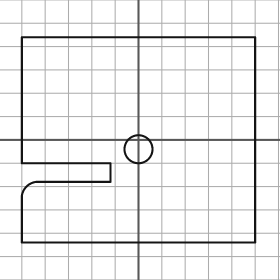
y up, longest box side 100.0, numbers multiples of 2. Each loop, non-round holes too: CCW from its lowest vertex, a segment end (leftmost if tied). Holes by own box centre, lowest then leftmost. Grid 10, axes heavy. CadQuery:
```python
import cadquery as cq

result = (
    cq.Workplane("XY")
    .moveTo(-50.0, -44.0)
    .lineTo(50.0, -44.0)
    .lineTo(50.0, 44.0)
    .lineTo(-50.0, 44.0)
    .lineTo(-50.0, -10.0)
    .lineTo(-12.0, -10.0)
    .lineTo(-12.0, -18.0)
    .lineTo(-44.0, -18.0)
    .threePointArc((-48.0, -20.0), (-50.0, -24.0))
    .close()
    .moveTo(0.0, -4.0)
    .circle(6.0)
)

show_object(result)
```